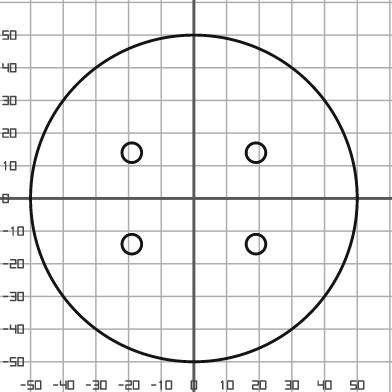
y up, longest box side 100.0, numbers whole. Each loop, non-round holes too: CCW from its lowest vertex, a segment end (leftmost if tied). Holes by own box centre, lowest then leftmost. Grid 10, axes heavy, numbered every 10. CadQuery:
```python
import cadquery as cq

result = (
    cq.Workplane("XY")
    .moveTo(0.0, 0.0)
    .circle(50.0)
    .moveTo(-19.0, -14.0)
    .circle(3.0)
    .moveTo(19.0, -14.0)
    .circle(3.0)
    .moveTo(-19.0, 14.0)
    .circle(3.0)
    .moveTo(19.0, 14.0)
    .circle(3.0)
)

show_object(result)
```